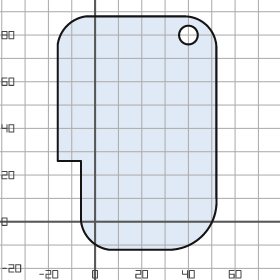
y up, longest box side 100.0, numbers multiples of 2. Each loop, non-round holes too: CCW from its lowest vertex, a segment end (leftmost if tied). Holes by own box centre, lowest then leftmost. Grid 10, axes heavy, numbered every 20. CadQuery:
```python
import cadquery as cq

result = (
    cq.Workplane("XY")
    .moveTo(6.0, -12.0)
    .lineTo(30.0, -12.0)
    .threePointArc((46.0, -6.0), (52.0, 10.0))
    .lineTo(52.0, 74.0)
    .threePointArc((48.0, 84.0), (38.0, 88.0))
    .lineTo(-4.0, 88.0)
    .threePointArc((-12.0, 84.0), (-16.0, 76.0))
    .lineTo(-16.0, 26.0)
    .lineTo(-6.0, 26.0)
    .lineTo(-6.0, 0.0)
    .threePointArc((-2.0, -8.0), (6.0, -12.0))
    .close()
    .moveTo(40.0, 80.0)
    .circle(4.0)
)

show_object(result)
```